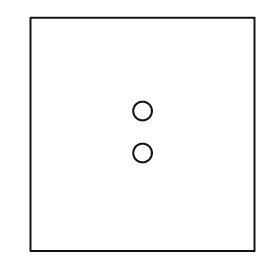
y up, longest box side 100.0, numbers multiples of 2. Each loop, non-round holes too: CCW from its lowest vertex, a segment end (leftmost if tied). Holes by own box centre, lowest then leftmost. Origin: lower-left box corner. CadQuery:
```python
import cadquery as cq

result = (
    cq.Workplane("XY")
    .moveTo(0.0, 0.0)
    .lineTo(96.0, 0.0)
    .lineTo(96.0, 100.0)
    .lineTo(0.0, 100.0)
    .close()
    .moveTo(48.0, 42.0)
    .circle(4.0)
    .moveTo(48.0, 60.0)
    .circle(4.0)
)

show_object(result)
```